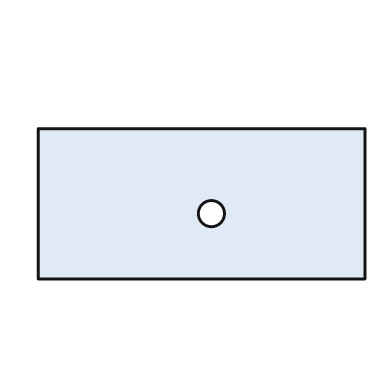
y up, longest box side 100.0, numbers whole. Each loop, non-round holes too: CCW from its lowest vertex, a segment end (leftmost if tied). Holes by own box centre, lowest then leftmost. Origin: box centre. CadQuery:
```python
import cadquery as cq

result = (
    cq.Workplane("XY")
    .moveTo(-50.0, -23.0)
    .lineTo(50.0, -23.0)
    .lineTo(50.0, 23.0)
    .lineTo(-50.0, 23.0)
    .close()
    .moveTo(3.0, -3.0)
    .circle(4.0)
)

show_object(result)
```